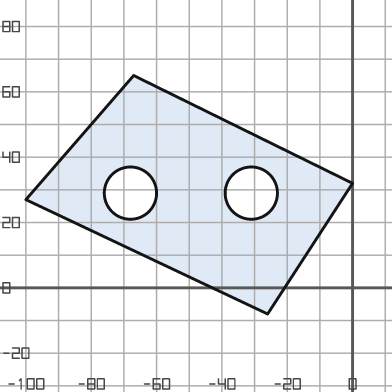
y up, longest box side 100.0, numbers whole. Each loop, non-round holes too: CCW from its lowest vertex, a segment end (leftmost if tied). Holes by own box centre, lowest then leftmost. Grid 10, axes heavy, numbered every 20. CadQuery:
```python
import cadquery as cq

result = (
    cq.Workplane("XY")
    .moveTo(-26.0, -8.0)
    .lineTo(0.0, 32.0)
    .lineTo(-67.0, 65.0)
    .lineTo(-100.0, 27.0)
    .close()
    .moveTo(-68.0, 29.0)
    .circle(8.0)
    .moveTo(-31.0, 29.0)
    .circle(8.0)
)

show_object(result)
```